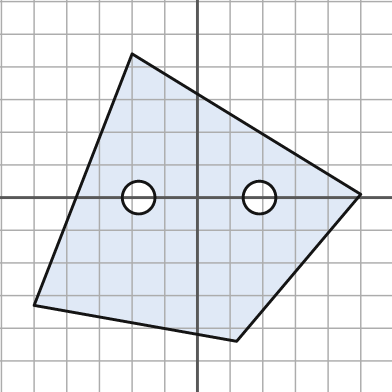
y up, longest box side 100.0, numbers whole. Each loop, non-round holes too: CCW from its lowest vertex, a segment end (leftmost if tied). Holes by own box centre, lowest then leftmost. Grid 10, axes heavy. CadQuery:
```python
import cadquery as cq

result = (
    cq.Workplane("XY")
    .moveTo(12.0, -44.0)
    .lineTo(50.0, 1.0)
    .lineTo(-20.0, 44.0)
    .lineTo(-50.0, -33.0)
    .close()
    .moveTo(-18.0, 0.0)
    .circle(5.0)
    .moveTo(19.0, 0.0)
    .circle(5.0)
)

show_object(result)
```